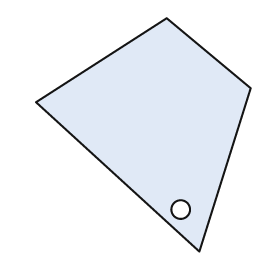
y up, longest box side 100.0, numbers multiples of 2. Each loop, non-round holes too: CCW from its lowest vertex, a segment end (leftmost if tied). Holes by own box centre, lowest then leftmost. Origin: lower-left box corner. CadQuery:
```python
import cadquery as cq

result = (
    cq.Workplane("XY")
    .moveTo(70.0, 0.0)
    .lineTo(92.0, 70.0)
    .lineTo(56.0, 100.0)
    .lineTo(0.0, 64.0)
    .close()
    .moveTo(62.0, 18.0)
    .circle(4.0)
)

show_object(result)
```